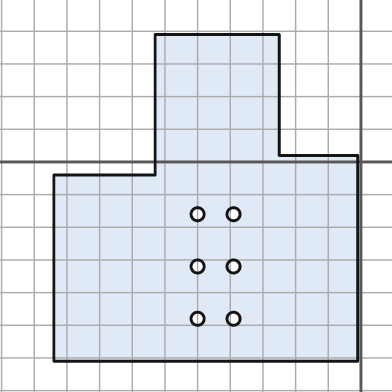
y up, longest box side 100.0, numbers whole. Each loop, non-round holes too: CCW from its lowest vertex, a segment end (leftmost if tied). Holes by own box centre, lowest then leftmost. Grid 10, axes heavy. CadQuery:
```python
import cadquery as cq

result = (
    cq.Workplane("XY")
    .moveTo(-94.0, -61.0)
    .lineTo(-1.0, -61.0)
    .lineTo(-1.0, 2.0)
    .lineTo(-25.0, 2.0)
    .lineTo(-25.0, 39.0)
    .lineTo(-63.0, 39.0)
    .lineTo(-63.0, -4.0)
    .lineTo(-94.0, -4.0)
    .close()
    .moveTo(-50.0, -48.0)
    .circle(2.0)
    .moveTo(-39.0, -48.0)
    .circle(2.0)
    .moveTo(-50.0, -32.0)
    .circle(2.0)
    .moveTo(-39.0, -32.0)
    .circle(2.0)
    .moveTo(-50.0, -16.0)
    .circle(2.0)
    .moveTo(-39.0, -16.0)
    .circle(2.0)
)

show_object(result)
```